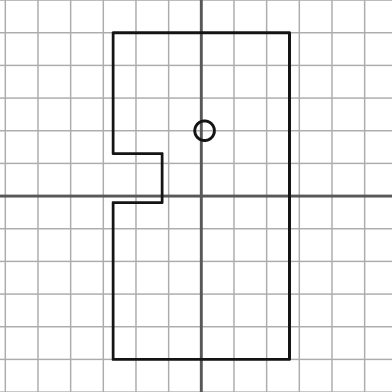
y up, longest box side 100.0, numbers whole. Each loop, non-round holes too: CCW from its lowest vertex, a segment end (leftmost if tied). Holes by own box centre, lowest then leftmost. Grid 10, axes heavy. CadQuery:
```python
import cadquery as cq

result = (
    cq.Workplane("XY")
    .moveTo(-27.0, -50.0)
    .lineTo(27.0, -50.0)
    .lineTo(27.0, 50.0)
    .lineTo(-27.0, 50.0)
    .lineTo(-27.0, 13.0)
    .lineTo(-12.0, 13.0)
    .lineTo(-12.0, -2.0)
    .lineTo(-27.0, -2.0)
    .close()
    .moveTo(1.0, 20.0)
    .circle(3.0)
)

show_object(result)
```